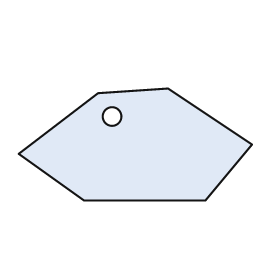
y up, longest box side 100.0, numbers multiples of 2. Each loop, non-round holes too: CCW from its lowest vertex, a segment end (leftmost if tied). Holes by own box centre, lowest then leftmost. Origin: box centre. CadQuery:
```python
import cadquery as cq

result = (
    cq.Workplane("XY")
    .moveTo(-22.0, -24.0)
    .lineTo(30.0, -24.0)
    .lineTo(50.0, 0.0)
    .lineTo(14.0, 24.0)
    .lineTo(-16.0, 22.0)
    .lineTo(-50.0, -4.0)
    .close()
    .moveTo(-10.0, 12.0)
    .circle(4.0)
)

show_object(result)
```